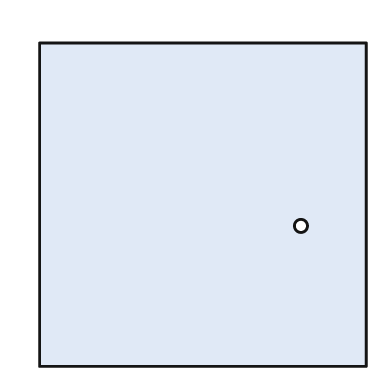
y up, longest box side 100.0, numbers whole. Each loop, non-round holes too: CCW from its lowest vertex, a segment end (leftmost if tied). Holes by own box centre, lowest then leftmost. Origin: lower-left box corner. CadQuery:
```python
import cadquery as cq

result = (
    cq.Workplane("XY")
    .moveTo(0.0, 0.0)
    .lineTo(100.0, 0.0)
    .lineTo(100.0, 99.0)
    .lineTo(0.0, 99.0)
    .close()
    .moveTo(80.0, 43.0)
    .circle(2.0)
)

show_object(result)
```